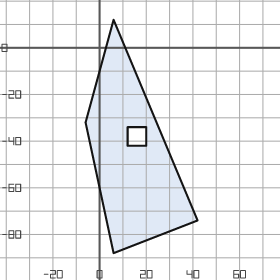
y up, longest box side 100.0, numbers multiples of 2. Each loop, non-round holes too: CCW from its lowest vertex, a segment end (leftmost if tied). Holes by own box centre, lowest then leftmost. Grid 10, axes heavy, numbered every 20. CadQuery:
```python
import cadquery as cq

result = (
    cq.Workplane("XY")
    .moveTo(6.0, -88.0)
    .lineTo(42.0, -74.0)
    .lineTo(6.0, 12.0)
    .lineTo(-6.0, -32.0)
    .close()
    .moveTo(12.0, -42.0)
    .lineTo(20.0, -42.0)
    .lineTo(20.0, -34.0)
    .lineTo(12.0, -34.0)
    .close()
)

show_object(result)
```